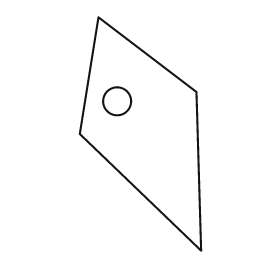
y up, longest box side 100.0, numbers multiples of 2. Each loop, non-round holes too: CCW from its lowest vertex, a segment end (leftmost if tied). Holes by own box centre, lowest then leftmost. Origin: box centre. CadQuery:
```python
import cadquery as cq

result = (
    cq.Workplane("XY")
    .moveTo(26.0, -50.0)
    .lineTo(24.0, 18.0)
    .lineTo(-18.0, 50.0)
    .lineTo(-26.0, 0.0)
    .close()
    .moveTo(-10.0, 14.0)
    .circle(6.0)
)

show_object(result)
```